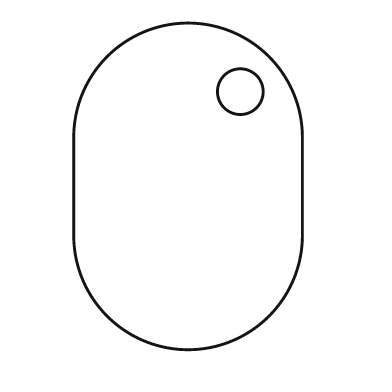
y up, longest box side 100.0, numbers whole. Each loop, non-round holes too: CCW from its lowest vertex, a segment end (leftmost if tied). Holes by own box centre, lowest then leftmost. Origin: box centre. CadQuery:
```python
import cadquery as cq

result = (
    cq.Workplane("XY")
    .moveTo(-35.0, -15.0)
    .threePointArc((0.0, -50.0), (35.0, -15.0))
    .lineTo(35.0, 15.0)
    .threePointArc((0.0, 50.0), (-35.0, 15.0))
    .close()
    .moveTo(16.0, 29.0)
    .circle(7.0)
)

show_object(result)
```